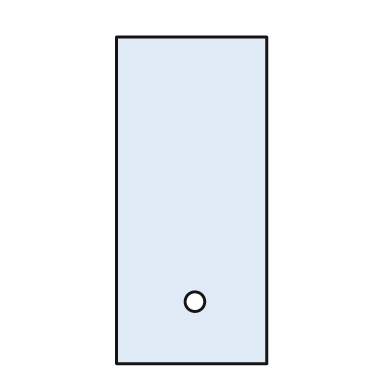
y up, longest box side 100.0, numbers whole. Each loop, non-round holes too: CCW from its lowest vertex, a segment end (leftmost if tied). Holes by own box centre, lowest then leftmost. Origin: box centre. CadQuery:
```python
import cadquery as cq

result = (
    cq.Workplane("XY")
    .moveTo(-23.0, -50.0)
    .lineTo(23.0, -50.0)
    .lineTo(23.0, 50.0)
    .lineTo(-23.0, 50.0)
    .close()
    .moveTo(1.0, -31.0)
    .circle(3.0)
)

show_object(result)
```